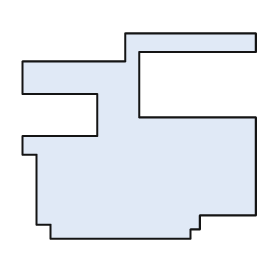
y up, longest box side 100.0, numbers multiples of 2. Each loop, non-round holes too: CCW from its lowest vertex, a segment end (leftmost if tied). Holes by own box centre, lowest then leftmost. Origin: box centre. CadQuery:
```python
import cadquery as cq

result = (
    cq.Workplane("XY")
    .moveTo(-38.0, -44.0)
    .lineTo(22.0, -44.0)
    .lineTo(22.0, -40.0)
    .lineTo(26.0, -40.0)
    .lineTo(26.0, -34.0)
    .lineTo(50.0, -34.0)
    .lineTo(50.0, 8.0)
    .lineTo(0.0, 8.0)
    .lineTo(0.0, 36.0)
    .lineTo(50.0, 36.0)
    .lineTo(50.0, 44.0)
    .lineTo(-6.0, 44.0)
    .lineTo(-6.0, 32.0)
    .lineTo(-50.0, 32.0)
    .lineTo(-50.0, 18.0)
    .lineTo(-18.0, 18.0)
    .lineTo(-18.0, 0.0)
    .lineTo(-50.0, 0.0)
    .lineTo(-50.0, -8.0)
    .lineTo(-44.0, -8.0)
    .lineTo(-44.0, -38.0)
    .lineTo(-38.0, -38.0)
    .close()
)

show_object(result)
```